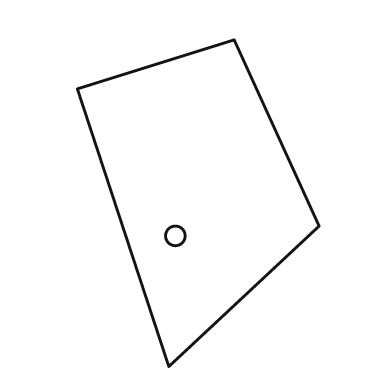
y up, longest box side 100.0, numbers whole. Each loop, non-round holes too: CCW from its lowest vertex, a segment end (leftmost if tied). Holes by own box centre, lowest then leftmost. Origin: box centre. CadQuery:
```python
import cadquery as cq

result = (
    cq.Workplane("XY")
    .moveTo(-9.0, -50.0)
    .lineTo(37.0, -7.0)
    .lineTo(11.0, 50.0)
    .lineTo(-37.0, 35.0)
    .close()
    .moveTo(-7.0, -10.0)
    .circle(3.0)
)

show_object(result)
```